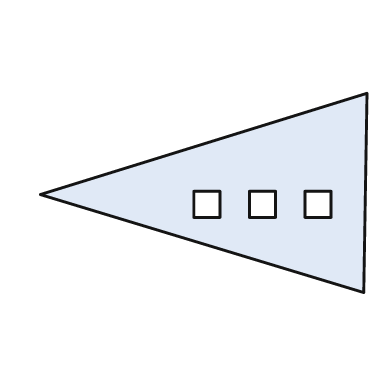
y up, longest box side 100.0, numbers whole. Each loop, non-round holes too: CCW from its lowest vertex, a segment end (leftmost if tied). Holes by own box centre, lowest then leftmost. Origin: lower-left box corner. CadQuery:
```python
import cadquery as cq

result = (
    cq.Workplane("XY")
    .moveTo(99.0, 0.0)
    .lineTo(100.0, 61.0)
    .lineTo(0.0, 30.0)
    .close()
    .moveTo(47.0, 23.0)
    .lineTo(55.0, 23.0)
    .lineTo(55.0, 31.0)
    .lineTo(47.0, 31.0)
    .close()
    .moveTo(64.0, 23.0)
    .lineTo(72.0, 23.0)
    .lineTo(72.0, 31.0)
    .lineTo(64.0, 31.0)
    .close()
    .moveTo(81.0, 23.0)
    .lineTo(89.0, 23.0)
    .lineTo(89.0, 31.0)
    .lineTo(81.0, 31.0)
    .close()
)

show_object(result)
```